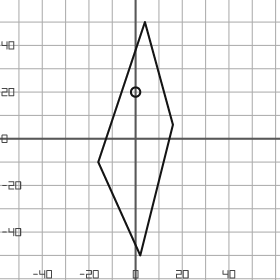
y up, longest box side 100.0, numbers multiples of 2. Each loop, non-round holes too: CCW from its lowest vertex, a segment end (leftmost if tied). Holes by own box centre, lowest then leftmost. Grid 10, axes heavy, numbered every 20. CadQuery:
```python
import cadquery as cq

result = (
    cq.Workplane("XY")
    .moveTo(2.0, -50.0)
    .lineTo(16.0, 6.0)
    .lineTo(4.0, 50.0)
    .lineTo(-16.0, -10.0)
    .close()
    .moveTo(0.0, 20.0)
    .circle(2.0)
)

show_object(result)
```